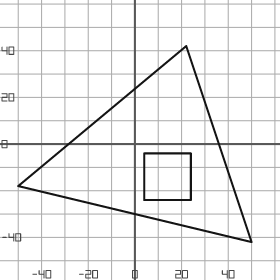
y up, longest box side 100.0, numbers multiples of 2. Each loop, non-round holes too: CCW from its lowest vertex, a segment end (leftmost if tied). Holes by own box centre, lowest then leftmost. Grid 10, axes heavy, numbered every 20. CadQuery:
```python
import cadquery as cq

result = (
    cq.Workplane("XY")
    .moveTo(50.0, -42.0)
    .lineTo(22.0, 42.0)
    .lineTo(-50.0, -18.0)
    .close()
    .moveTo(4.0, -24.0)
    .lineTo(24.0, -24.0)
    .lineTo(24.0, -4.0)
    .lineTo(4.0, -4.0)
    .close()
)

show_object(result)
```